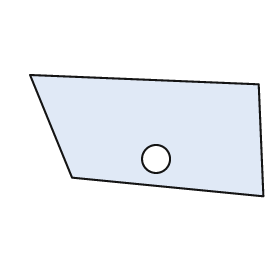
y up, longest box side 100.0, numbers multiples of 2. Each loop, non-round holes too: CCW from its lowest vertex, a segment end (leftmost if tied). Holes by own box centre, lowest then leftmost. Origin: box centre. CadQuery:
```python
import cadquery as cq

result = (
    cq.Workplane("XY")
    .moveTo(50.0, -26.0)
    .lineTo(48.0, 22.0)
    .lineTo(-50.0, 26.0)
    .lineTo(-32.0, -18.0)
    .close()
    .moveTo(4.0, -10.0)
    .circle(6.0)
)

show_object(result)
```